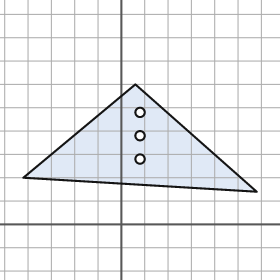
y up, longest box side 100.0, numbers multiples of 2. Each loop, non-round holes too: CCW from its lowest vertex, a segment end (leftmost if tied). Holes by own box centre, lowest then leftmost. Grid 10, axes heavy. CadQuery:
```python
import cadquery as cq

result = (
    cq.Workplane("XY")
    .moveTo(58.0, 14.0)
    .lineTo(6.0, 60.0)
    .lineTo(-42.0, 20.0)
    .close()
    .moveTo(8.0, 28.0)
    .circle(2.0)
    .moveTo(8.0, 38.0)
    .circle(2.0)
    .moveTo(8.0, 48.0)
    .circle(2.0)
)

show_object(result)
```